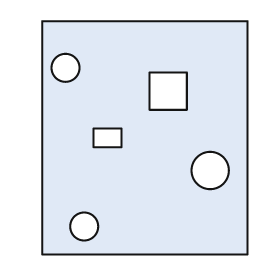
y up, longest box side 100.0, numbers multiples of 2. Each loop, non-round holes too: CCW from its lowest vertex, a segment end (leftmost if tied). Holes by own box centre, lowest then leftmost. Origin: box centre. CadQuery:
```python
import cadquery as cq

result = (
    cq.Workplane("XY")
    .moveTo(-44.0, -50.0)
    .lineTo(44.0, -50.0)
    .lineTo(44.0, 50.0)
    .lineTo(-44.0, 50.0)
    .close()
    .moveTo(-26.0, -38.0)
    .circle(6.0)
    .moveTo(28.0, -14.0)
    .circle(8.0)
    .moveTo(-22.0, -4.0)
    .lineTo(-10.0, -4.0)
    .lineTo(-10.0, 4.0)
    .lineTo(-22.0, 4.0)
    .close()
    .moveTo(2.0, 12.0)
    .lineTo(18.0, 12.0)
    .lineTo(18.0, 28.0)
    .lineTo(2.0, 28.0)
    .close()
    .moveTo(-34.0, 30.0)
    .circle(6.0)
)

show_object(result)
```